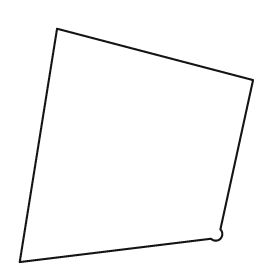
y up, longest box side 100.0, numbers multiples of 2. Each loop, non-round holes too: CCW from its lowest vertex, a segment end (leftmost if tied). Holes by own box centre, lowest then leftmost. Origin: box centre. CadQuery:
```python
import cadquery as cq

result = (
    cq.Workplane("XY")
    .moveTo(-50.0, -50.0)
    .lineTo(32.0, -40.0)
    .threePointArc((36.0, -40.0), (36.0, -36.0))
    .lineTo(50.0, 28.0)
    .lineTo(-34.0, 50.0)
    .close()
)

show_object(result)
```